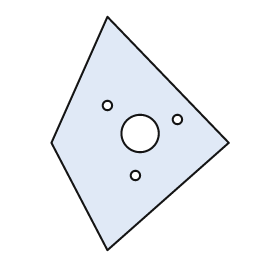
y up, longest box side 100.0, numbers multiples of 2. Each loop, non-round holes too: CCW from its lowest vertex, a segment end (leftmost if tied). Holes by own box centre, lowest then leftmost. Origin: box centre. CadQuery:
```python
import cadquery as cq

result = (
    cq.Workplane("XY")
    .moveTo(-14.0, -50.0)
    .lineTo(38.0, -4.0)
    .lineTo(-14.0, 50.0)
    .lineTo(-38.0, -4.0)
    .close()
    .moveTo(-2.0, -18.0)
    .circle(2.0)
    .moveTo(0.0, 0.0)
    .circle(8.0)
    .moveTo(16.0, 6.0)
    .circle(2.0)
    .moveTo(-14.0, 12.0)
    .circle(2.0)
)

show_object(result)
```